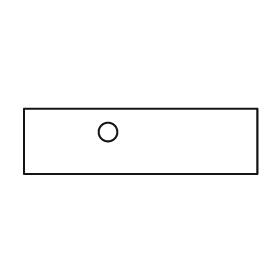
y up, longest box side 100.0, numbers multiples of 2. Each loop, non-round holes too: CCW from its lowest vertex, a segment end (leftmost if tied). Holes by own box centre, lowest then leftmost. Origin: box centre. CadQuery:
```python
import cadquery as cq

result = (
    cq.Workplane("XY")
    .moveTo(-50.0, -14.0)
    .lineTo(50.0, -14.0)
    .lineTo(50.0, 14.0)
    .lineTo(-50.0, 14.0)
    .close()
    .moveTo(-14.0, 4.0)
    .circle(4.0)
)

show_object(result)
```